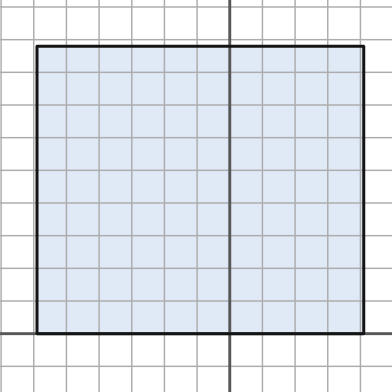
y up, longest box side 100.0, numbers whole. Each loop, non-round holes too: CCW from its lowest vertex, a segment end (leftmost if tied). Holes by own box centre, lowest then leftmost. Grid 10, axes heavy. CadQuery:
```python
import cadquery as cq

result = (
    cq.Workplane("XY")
    .moveTo(-59.0, 0.0)
    .lineTo(41.0, 0.0)
    .lineTo(41.0, 88.0)
    .lineTo(-59.0, 88.0)
    .close()
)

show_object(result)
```